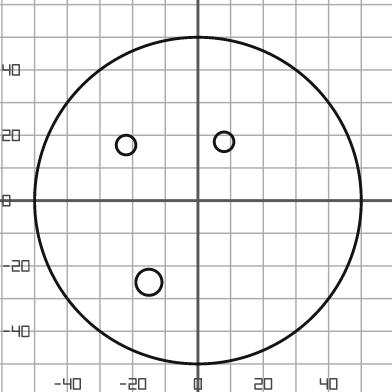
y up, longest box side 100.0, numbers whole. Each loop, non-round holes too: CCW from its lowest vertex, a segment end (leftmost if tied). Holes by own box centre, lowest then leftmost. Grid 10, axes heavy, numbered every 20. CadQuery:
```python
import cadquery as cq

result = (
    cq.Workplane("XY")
    .moveTo(0.0, 0.0)
    .circle(50.0)
    .moveTo(-15.0, -25.0)
    .circle(4.0)
    .moveTo(-22.0, 17.0)
    .circle(3.0)
    .moveTo(8.0, 18.0)
    .circle(3.0)
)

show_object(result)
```